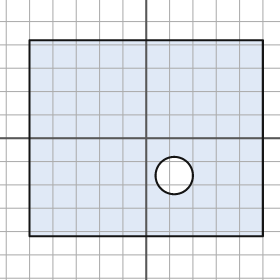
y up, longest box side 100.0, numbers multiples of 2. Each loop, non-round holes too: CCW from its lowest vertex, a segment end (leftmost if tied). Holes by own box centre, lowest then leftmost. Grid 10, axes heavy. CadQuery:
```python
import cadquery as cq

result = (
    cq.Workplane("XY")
    .moveTo(-50.0, -42.0)
    .lineTo(50.0, -42.0)
    .lineTo(50.0, 42.0)
    .lineTo(-50.0, 42.0)
    .close()
    .moveTo(12.0, -16.0)
    .circle(8.0)
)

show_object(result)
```